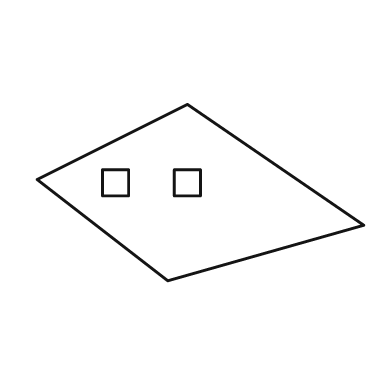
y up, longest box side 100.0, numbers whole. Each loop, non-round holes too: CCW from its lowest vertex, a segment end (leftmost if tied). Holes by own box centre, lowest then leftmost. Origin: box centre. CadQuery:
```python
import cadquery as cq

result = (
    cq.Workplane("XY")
    .moveTo(-10.0, -27.0)
    .lineTo(50.0, -10.0)
    .lineTo(-4.0, 27.0)
    .lineTo(-50.0, 4.0)
    .close()
    .moveTo(-30.0, -1.0)
    .lineTo(-22.0, -1.0)
    .lineTo(-22.0, 7.0)
    .lineTo(-30.0, 7.0)
    .close()
    .moveTo(-8.0, -1.0)
    .lineTo(0.0, -1.0)
    .lineTo(0.0, 7.0)
    .lineTo(-8.0, 7.0)
    .close()
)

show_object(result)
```